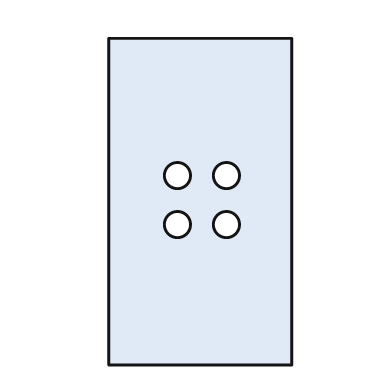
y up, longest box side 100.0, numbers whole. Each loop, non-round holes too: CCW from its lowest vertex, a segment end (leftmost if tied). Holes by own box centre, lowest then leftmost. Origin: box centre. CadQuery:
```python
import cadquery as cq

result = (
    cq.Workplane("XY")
    .moveTo(-28.0, -50.0)
    .lineTo(28.0, -50.0)
    .lineTo(28.0, 50.0)
    .lineTo(-28.0, 50.0)
    .close()
    .moveTo(-7.0, -7.0)
    .circle(4.0)
    .moveTo(8.0, -7.0)
    .circle(4.0)
    .moveTo(-7.0, 8.0)
    .circle(4.0)
    .moveTo(8.0, 8.0)
    .circle(4.0)
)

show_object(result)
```